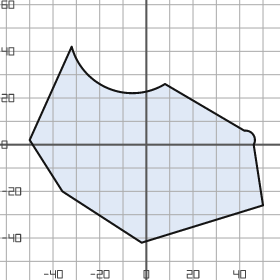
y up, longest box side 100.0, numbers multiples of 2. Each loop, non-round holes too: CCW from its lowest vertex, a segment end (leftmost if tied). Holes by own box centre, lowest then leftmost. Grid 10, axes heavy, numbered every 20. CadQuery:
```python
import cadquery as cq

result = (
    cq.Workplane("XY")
    .moveTo(-2.0, -42.0)
    .lineTo(50.0, -26.0)
    .lineTo(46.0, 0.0)
    .threePointArc((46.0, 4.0), (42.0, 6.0))
    .lineTo(8.0, 26.0)
    .threePointArc((-16.0, 24.0), (-32.0, 42.0))
    .lineTo(-50.0, 2.0)
    .lineTo(-36.0, -20.0)
    .close()
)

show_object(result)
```